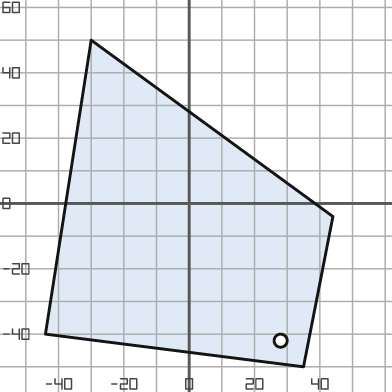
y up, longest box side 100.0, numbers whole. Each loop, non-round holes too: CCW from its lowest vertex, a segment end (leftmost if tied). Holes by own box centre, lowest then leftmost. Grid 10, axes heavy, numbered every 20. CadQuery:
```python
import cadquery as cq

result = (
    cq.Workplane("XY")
    .moveTo(35.0, -50.0)
    .lineTo(44.0, -4.0)
    .lineTo(-30.0, 50.0)
    .lineTo(-44.0, -40.0)
    .close()
    .moveTo(28.0, -42.0)
    .circle(2.0)
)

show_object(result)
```